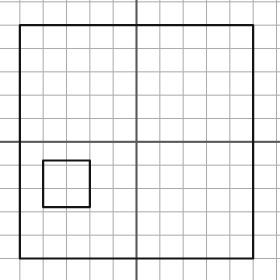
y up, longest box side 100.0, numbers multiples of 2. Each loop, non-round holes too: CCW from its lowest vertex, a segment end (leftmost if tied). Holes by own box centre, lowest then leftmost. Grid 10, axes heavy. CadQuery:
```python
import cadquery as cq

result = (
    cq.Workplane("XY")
    .moveTo(-50.0, -50.0)
    .lineTo(50.0, -50.0)
    .lineTo(50.0, 50.0)
    .lineTo(-50.0, 50.0)
    .close()
    .moveTo(-40.0, -28.0)
    .lineTo(-20.0, -28.0)
    .lineTo(-20.0, -8.0)
    .lineTo(-40.0, -8.0)
    .close()
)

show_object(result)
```